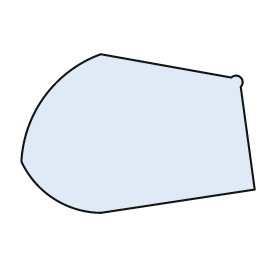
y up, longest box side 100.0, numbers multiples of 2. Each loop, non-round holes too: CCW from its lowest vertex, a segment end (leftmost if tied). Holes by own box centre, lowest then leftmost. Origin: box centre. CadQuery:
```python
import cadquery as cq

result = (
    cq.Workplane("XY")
    .moveTo(-16.0, -34.0)
    .lineTo(50.0, -24.0)
    .lineTo(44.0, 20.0)
    .threePointArc((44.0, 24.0), (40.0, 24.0))
    .lineTo(-16.0, 34.0)
    .threePointArc((-40.0, 16.0), (-50.0, -12.0))
    .threePointArc((-36.0, -28.0), (-16.0, -34.0))
    .close()
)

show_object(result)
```